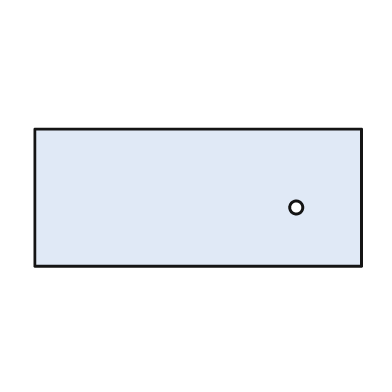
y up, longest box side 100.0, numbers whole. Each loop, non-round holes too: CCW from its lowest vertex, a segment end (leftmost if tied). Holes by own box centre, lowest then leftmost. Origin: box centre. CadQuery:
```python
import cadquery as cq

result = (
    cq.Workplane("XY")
    .moveTo(-50.0, -21.0)
    .lineTo(50.0, -21.0)
    .lineTo(50.0, 21.0)
    .lineTo(-50.0, 21.0)
    .close()
    .moveTo(30.0, -3.0)
    .circle(2.0)
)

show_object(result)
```